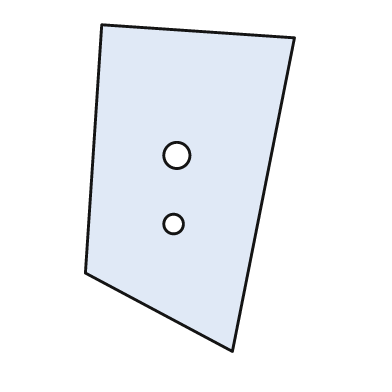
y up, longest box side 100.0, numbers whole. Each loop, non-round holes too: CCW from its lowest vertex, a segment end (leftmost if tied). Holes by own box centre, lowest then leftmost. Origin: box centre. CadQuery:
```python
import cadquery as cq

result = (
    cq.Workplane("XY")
    .moveTo(13.0, -50.0)
    .lineTo(32.0, 46.0)
    .lineTo(-27.0, 50.0)
    .lineTo(-32.0, -26.0)
    .close()
    .moveTo(-5.0, -11.0)
    .circle(3.0)
    .moveTo(-4.0, 10.0)
    .circle(4.0)
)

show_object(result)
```